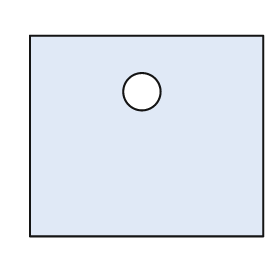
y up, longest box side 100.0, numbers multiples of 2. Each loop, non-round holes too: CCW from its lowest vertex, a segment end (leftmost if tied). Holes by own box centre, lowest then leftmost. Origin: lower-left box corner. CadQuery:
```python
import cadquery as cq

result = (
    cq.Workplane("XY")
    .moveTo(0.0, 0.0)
    .lineTo(100.0, 0.0)
    .lineTo(100.0, 86.0)
    .lineTo(0.0, 86.0)
    .close()
    .moveTo(48.0, 62.0)
    .circle(8.0)
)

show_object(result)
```